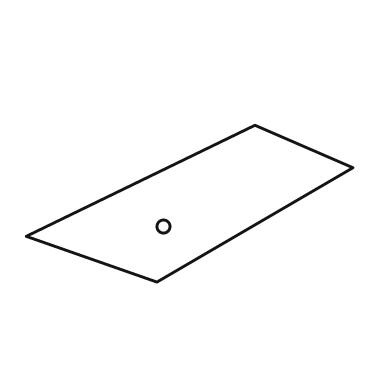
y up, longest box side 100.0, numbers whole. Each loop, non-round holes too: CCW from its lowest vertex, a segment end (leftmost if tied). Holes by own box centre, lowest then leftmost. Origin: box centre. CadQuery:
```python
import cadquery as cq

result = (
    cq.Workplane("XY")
    .moveTo(-10.0, -24.0)
    .lineTo(50.0, 11.0)
    .lineTo(20.0, 24.0)
    .lineTo(-50.0, -10.0)
    .close()
    .moveTo(-8.0, -7.0)
    .circle(2.0)
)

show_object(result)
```